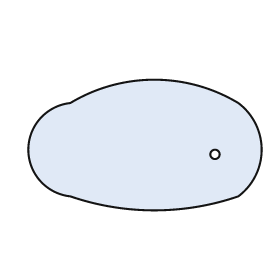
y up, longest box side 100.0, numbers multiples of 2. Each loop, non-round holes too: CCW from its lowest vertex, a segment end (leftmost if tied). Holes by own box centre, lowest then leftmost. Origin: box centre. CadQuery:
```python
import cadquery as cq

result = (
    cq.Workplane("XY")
    .moveTo(-32.0, -22.0)
    .threePointArc((4.0, -28.0), (40.0, -22.0))
    .threePointArc((50.0, -2.0), (40.0, 18.0))
    .threePointArc((4.0, 28.0), (-32.0, 18.0))
    .threePointArc((-50.0, -2.0), (-32.0, -22.0))
    .close()
    .moveTo(30.0, -4.0)
    .circle(2.0)
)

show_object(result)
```